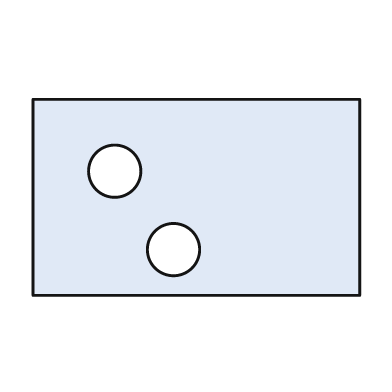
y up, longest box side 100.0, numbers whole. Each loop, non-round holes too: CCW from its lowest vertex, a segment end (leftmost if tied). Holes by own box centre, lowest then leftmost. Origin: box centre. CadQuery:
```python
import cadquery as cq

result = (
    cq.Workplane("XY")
    .moveTo(-50.0, -30.0)
    .lineTo(50.0, -30.0)
    .lineTo(50.0, 30.0)
    .lineTo(-50.0, 30.0)
    .close()
    .moveTo(-7.0, -16.0)
    .circle(8.0)
    .moveTo(-25.0, 8.0)
    .circle(8.0)
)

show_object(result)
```